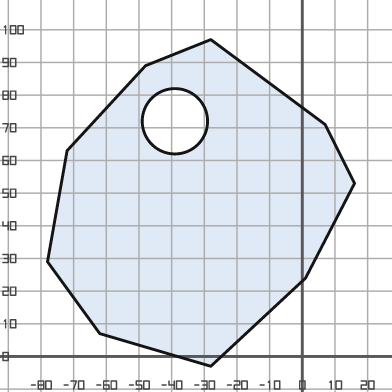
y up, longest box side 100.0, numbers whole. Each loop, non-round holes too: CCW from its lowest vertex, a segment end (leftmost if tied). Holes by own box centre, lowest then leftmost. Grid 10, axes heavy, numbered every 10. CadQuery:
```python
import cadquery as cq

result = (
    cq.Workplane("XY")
    .moveTo(-28.0, -3.0)
    .lineTo(1.0, 24.0)
    .lineTo(16.0, 53.0)
    .lineTo(7.0, 71.0)
    .lineTo(-28.0, 97.0)
    .lineTo(-48.0, 89.0)
    .lineTo(-72.0, 63.0)
    .lineTo(-78.0, 29.0)
    .lineTo(-62.0, 7.0)
    .close()
    .moveTo(-39.0, 72.0)
    .circle(10.0)
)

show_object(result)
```